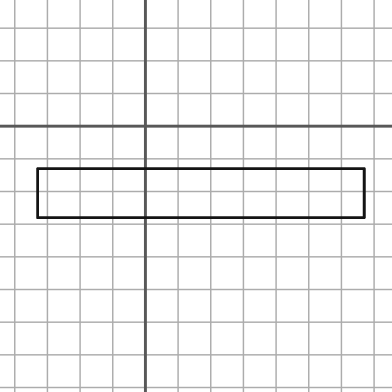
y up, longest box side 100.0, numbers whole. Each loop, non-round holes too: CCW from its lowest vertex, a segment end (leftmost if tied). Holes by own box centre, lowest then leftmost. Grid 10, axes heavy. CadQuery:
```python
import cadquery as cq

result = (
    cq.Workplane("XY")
    .moveTo(-33.0, -28.0)
    .lineTo(67.0, -28.0)
    .lineTo(67.0, -13.0)
    .lineTo(-33.0, -13.0)
    .close()
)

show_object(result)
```